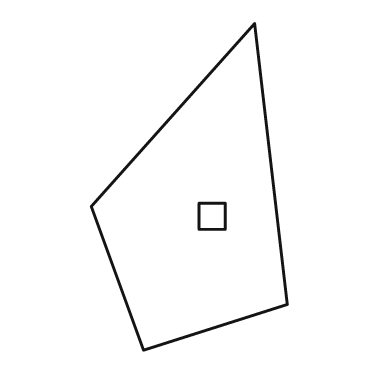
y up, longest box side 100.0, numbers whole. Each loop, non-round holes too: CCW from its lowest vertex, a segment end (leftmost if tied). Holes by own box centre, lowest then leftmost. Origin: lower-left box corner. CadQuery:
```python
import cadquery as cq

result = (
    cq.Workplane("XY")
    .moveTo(16.0, 0.0)
    .lineTo(60.0, 14.0)
    .lineTo(50.0, 100.0)
    .lineTo(0.0, 44.0)
    .close()
    .moveTo(33.0, 37.0)
    .lineTo(41.0, 37.0)
    .lineTo(41.0, 45.0)
    .lineTo(33.0, 45.0)
    .close()
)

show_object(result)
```